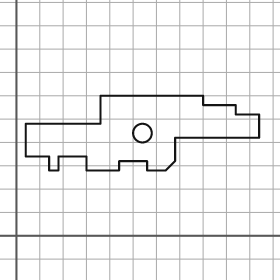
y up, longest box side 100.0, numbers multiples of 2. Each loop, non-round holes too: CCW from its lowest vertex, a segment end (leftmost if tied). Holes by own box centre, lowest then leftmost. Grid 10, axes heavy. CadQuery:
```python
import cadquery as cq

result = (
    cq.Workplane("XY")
    .moveTo(14.0, 28.0)
    .lineTo(18.0, 28.0)
    .lineTo(18.0, 34.0)
    .lineTo(30.0, 34.0)
    .lineTo(30.0, 28.0)
    .lineTo(44.0, 28.0)
    .lineTo(44.0, 32.0)
    .lineTo(56.0, 32.0)
    .lineTo(56.0, 28.0)
    .lineTo(64.0, 28.0)
    .lineTo(68.0, 32.0)
    .lineTo(68.0, 42.0)
    .lineTo(104.0, 42.0)
    .lineTo(104.0, 52.0)
    .lineTo(94.0, 52.0)
    .lineTo(94.0, 56.0)
    .lineTo(80.0, 56.0)
    .lineTo(80.0, 60.0)
    .lineTo(36.0, 60.0)
    .lineTo(36.0, 48.0)
    .lineTo(4.0, 48.0)
    .lineTo(4.0, 34.0)
    .lineTo(14.0, 34.0)
    .close()
    .moveTo(54.0, 44.0)
    .circle(4.0)
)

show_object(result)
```